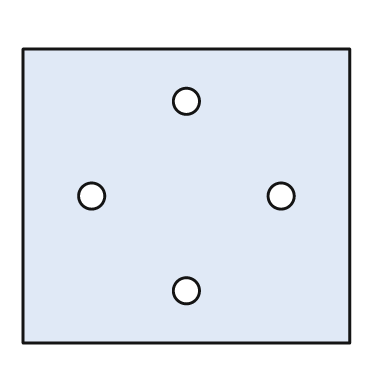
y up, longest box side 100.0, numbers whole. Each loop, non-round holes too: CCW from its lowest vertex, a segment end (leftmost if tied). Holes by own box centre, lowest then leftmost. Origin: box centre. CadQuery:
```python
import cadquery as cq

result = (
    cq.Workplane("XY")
    .moveTo(-50.0, -45.0)
    .lineTo(50.0, -45.0)
    .lineTo(50.0, 45.0)
    .lineTo(-50.0, 45.0)
    .close()
    .moveTo(0.0, -29.0)
    .circle(4.0)
    .moveTo(-29.0, 0.0)
    .circle(4.0)
    .moveTo(29.0, 0.0)
    .circle(4.0)
    .moveTo(0.0, 29.0)
    .circle(4.0)
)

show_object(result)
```